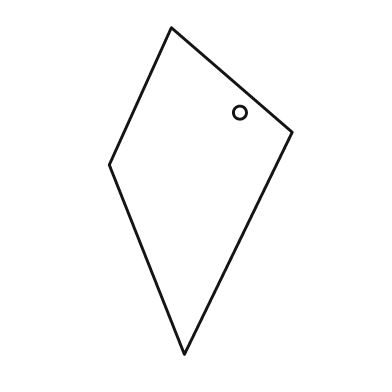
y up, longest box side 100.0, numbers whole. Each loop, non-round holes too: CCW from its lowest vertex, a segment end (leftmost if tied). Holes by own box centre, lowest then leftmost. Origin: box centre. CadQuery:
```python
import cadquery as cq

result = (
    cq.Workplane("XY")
    .moveTo(-5.0, -50.0)
    .lineTo(28.0, 18.0)
    .lineTo(-9.0, 50.0)
    .lineTo(-28.0, 8.0)
    .close()
    .moveTo(12.0, 24.0)
    .circle(2.0)
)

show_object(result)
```